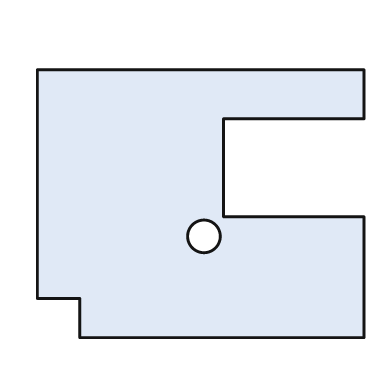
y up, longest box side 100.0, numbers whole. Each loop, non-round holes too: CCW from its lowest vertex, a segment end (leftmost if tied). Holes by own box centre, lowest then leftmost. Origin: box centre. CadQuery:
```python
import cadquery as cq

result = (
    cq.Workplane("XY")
    .moveTo(-37.0, -41.0)
    .lineTo(50.0, -41.0)
    .lineTo(50.0, -4.0)
    .lineTo(7.0, -4.0)
    .lineTo(7.0, 26.0)
    .lineTo(50.0, 26.0)
    .lineTo(50.0, 41.0)
    .lineTo(-50.0, 41.0)
    .lineTo(-50.0, -29.0)
    .lineTo(-37.0, -29.0)
    .close()
    .moveTo(1.0, -10.0)
    .circle(5.0)
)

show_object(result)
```